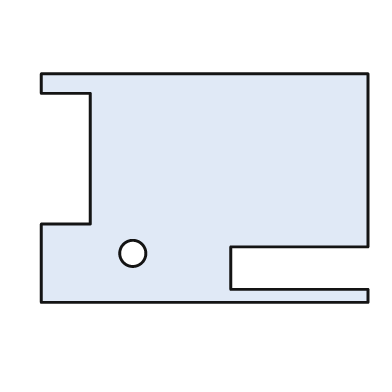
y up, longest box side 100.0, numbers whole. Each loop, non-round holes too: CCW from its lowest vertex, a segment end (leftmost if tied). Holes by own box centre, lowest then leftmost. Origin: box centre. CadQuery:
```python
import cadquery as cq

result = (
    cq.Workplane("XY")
    .moveTo(-50.0, -35.0)
    .lineTo(50.0, -35.0)
    .lineTo(50.0, -31.0)
    .lineTo(8.0, -31.0)
    .lineTo(8.0, -18.0)
    .lineTo(50.0, -18.0)
    .lineTo(50.0, 35.0)
    .lineTo(-50.0, 35.0)
    .lineTo(-50.0, 29.0)
    .lineTo(-35.0, 29.0)
    .lineTo(-35.0, -11.0)
    .lineTo(-50.0, -11.0)
    .close()
    .moveTo(-22.0, -20.0)
    .circle(4.0)
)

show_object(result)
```